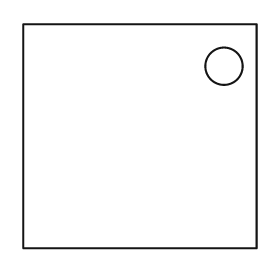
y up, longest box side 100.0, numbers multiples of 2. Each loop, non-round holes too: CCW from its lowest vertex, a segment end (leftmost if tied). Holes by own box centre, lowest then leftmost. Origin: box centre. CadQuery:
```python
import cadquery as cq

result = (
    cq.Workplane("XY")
    .moveTo(-50.0, -48.0)
    .lineTo(50.0, -48.0)
    .lineTo(50.0, 48.0)
    .lineTo(-50.0, 48.0)
    .close()
    .moveTo(36.0, 30.0)
    .circle(8.0)
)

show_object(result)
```